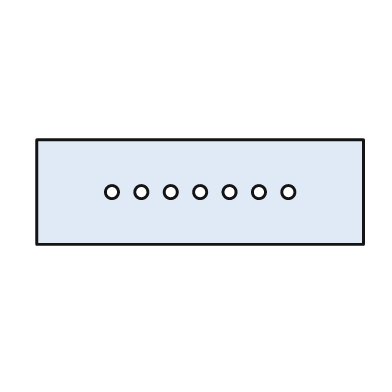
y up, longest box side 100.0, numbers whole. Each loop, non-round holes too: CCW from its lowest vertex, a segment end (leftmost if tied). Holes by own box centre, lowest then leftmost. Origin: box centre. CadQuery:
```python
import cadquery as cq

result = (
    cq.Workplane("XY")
    .moveTo(-50.0, -16.0)
    .lineTo(50.0, -16.0)
    .lineTo(50.0, 16.0)
    .lineTo(-50.0, 16.0)
    .close()
    .moveTo(-27.0, 0.0)
    .circle(2.0)
    .moveTo(-18.0, 0.0)
    .circle(2.0)
    .moveTo(-9.0, 0.0)
    .circle(2.0)
    .moveTo(0.0, 0.0)
    .circle(2.0)
    .moveTo(9.0, 0.0)
    .circle(2.0)
    .moveTo(18.0, 0.0)
    .circle(2.0)
    .moveTo(27.0, 0.0)
    .circle(2.0)
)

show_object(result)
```